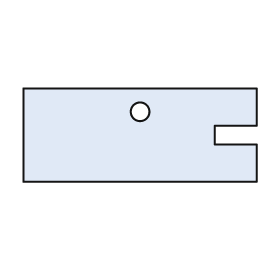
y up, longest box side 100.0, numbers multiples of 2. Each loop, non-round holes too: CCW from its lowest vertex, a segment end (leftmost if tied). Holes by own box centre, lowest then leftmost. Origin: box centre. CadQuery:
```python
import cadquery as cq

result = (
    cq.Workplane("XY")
    .moveTo(-50.0, -20.0)
    .lineTo(50.0, -20.0)
    .lineTo(50.0, -4.0)
    .lineTo(32.0, -4.0)
    .lineTo(32.0, 4.0)
    .lineTo(50.0, 4.0)
    .lineTo(50.0, 20.0)
    .lineTo(-50.0, 20.0)
    .close()
    .moveTo(0.0, 10.0)
    .circle(4.0)
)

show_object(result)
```